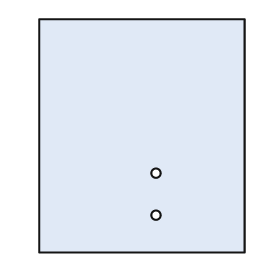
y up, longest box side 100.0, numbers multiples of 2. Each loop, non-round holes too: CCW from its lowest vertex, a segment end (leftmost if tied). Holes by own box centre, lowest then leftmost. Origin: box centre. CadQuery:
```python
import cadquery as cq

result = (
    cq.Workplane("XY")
    .moveTo(-44.0, -50.0)
    .lineTo(44.0, -50.0)
    .lineTo(44.0, 50.0)
    .lineTo(-44.0, 50.0)
    .close()
    .moveTo(6.0, -34.0)
    .circle(2.0)
    .moveTo(6.0, -16.0)
    .circle(2.0)
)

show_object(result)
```